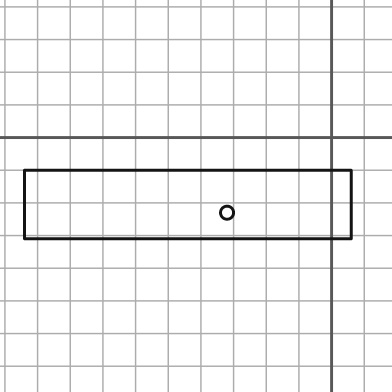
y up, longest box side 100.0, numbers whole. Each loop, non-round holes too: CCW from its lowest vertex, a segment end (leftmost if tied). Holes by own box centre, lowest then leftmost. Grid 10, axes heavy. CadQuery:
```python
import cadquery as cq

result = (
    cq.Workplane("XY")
    .moveTo(-94.0, -31.0)
    .lineTo(6.0, -31.0)
    .lineTo(6.0, -10.0)
    .lineTo(-94.0, -10.0)
    .close()
    .moveTo(-32.0, -23.0)
    .circle(2.0)
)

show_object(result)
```